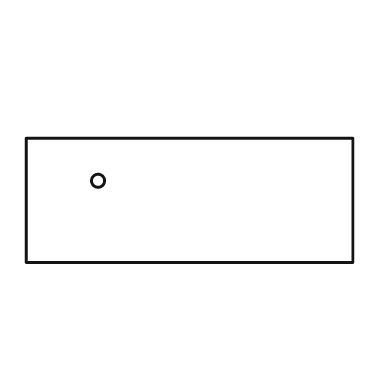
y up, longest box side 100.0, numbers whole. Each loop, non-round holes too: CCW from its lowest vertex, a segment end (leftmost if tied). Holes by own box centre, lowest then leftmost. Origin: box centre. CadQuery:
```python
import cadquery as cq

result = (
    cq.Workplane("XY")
    .moveTo(-50.0, -19.0)
    .lineTo(50.0, -19.0)
    .lineTo(50.0, 19.0)
    .lineTo(-50.0, 19.0)
    .close()
    .moveTo(-28.0, 6.0)
    .circle(2.0)
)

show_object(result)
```